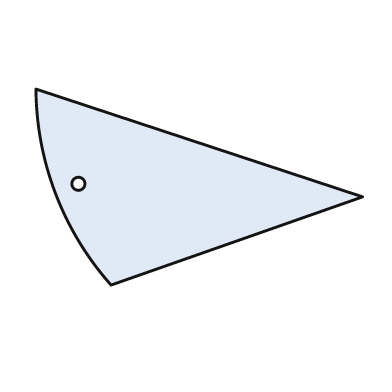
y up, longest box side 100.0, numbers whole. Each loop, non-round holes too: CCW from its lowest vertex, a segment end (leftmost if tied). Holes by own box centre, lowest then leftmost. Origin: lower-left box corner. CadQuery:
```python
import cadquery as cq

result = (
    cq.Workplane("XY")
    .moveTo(23.0, 0.0)
    .lineTo(100.0, 27.0)
    .lineTo(0.0, 60.0)
    .threePointArc((6.0, 28.0), (23.0, 0.0))
    .close()
    .moveTo(13.0, 31.0)
    .circle(2.0)
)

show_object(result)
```